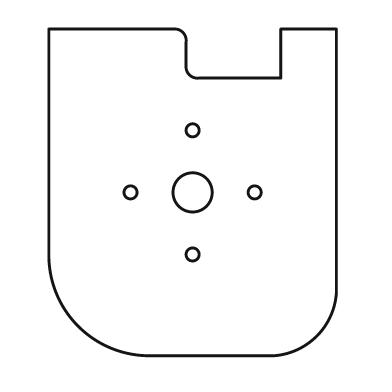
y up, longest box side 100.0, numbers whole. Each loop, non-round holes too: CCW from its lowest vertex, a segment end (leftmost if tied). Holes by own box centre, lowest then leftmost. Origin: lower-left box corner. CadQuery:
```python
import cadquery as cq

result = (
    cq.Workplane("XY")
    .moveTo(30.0, 0.0)
    .lineTo(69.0, 0.0)
    .threePointArc((82.0, 6.0), (88.0, 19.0))
    .lineTo(88.0, 100.0)
    .lineTo(71.0, 100.0)
    .lineTo(71.0, 85.0)
    .lineTo(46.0, 85.0)
    .threePointArc((43.0, 86.0), (42.0, 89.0))
    .lineTo(42.0, 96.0)
    .threePointArc((41.0, 99.0), (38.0, 100.0))
    .lineTo(0.0, 100.0)
    .lineTo(0.0, 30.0)
    .threePointArc((9.0, 9.0), (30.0, 0.0))
    .close()
    .moveTo(44.0, 31.0)
    .circle(2.0)
    .moveTo(25.0, 50.0)
    .circle(2.0)
    .moveTo(44.0, 50.0)
    .circle(6.0)
    .moveTo(63.0, 50.0)
    .circle(2.0)
    .moveTo(44.0, 69.0)
    .circle(2.0)
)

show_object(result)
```